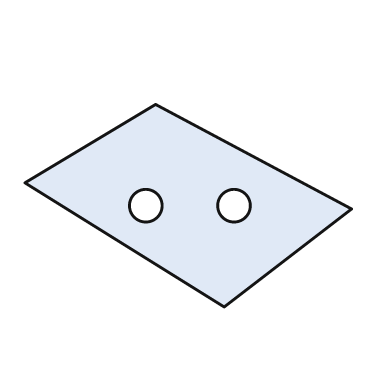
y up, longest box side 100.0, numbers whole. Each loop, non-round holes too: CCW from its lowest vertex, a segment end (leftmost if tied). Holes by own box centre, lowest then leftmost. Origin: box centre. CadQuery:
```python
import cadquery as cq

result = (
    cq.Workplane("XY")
    .moveTo(11.0, -31.0)
    .lineTo(50.0, -1.0)
    .lineTo(-10.0, 31.0)
    .lineTo(-50.0, 7.0)
    .close()
    .moveTo(-13.0, 0.0)
    .circle(5.0)
    .moveTo(14.0, 0.0)
    .circle(5.0)
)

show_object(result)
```